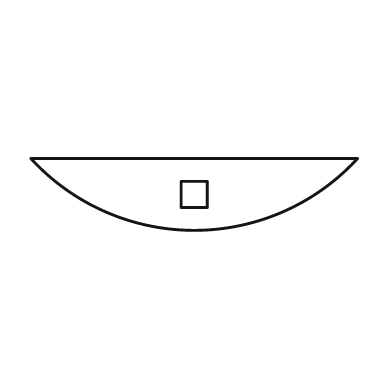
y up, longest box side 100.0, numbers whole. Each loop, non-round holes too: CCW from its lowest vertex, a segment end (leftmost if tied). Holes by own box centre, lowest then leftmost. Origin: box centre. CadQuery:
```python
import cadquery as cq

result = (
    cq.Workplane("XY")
    .moveTo(-50.0, 11.0)
    .threePointArc((0.0, -11.0), (50.0, 11.0))
    .close()
    .moveTo(-4.0, -4.0)
    .lineTo(4.0, -4.0)
    .lineTo(4.0, 4.0)
    .lineTo(-4.0, 4.0)
    .close()
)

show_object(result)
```